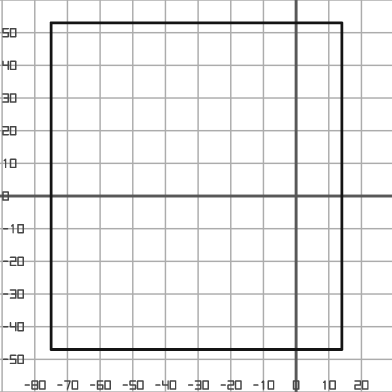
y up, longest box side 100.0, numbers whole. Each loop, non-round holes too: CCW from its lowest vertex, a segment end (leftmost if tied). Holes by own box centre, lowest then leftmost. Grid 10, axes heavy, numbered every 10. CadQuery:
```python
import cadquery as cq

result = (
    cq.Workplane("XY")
    .moveTo(-75.0, -47.0)
    .lineTo(14.0, -47.0)
    .lineTo(14.0, 53.0)
    .lineTo(-75.0, 53.0)
    .close()
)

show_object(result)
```